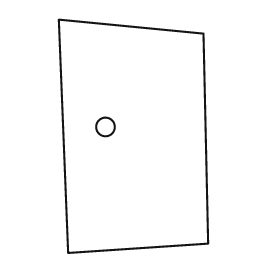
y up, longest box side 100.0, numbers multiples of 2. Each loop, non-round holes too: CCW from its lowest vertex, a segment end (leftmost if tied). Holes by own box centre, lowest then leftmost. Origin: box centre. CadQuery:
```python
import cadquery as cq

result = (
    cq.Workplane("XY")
    .moveTo(-28.0, -50.0)
    .lineTo(32.0, -46.0)
    .lineTo(30.0, 44.0)
    .lineTo(-32.0, 50.0)
    .close()
    .moveTo(-12.0, 4.0)
    .circle(4.0)
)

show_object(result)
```